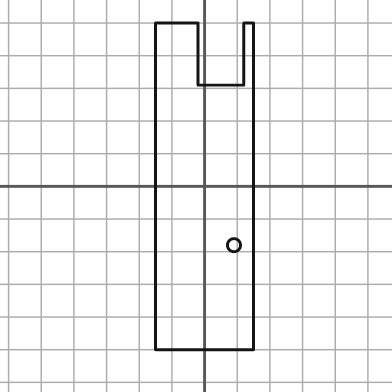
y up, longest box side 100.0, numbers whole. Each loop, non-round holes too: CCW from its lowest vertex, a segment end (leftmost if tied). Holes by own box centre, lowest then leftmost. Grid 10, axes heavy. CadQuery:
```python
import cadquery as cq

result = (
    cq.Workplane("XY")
    .moveTo(-15.0, -50.0)
    .lineTo(15.0, -50.0)
    .lineTo(15.0, 50.0)
    .lineTo(12.0, 50.0)
    .lineTo(12.0, 31.0)
    .lineTo(-2.0, 31.0)
    .lineTo(-2.0, 50.0)
    .lineTo(-15.0, 50.0)
    .close()
    .moveTo(9.0, -18.0)
    .circle(2.0)
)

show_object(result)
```